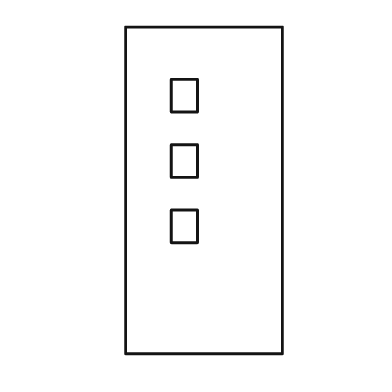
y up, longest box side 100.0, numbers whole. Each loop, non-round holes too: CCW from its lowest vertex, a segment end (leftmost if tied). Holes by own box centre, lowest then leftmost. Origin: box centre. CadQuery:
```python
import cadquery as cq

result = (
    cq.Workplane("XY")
    .moveTo(-24.0, -50.0)
    .lineTo(24.0, -50.0)
    .lineTo(24.0, 50.0)
    .lineTo(-24.0, 50.0)
    .close()
    .moveTo(-10.0, -16.0)
    .lineTo(-2.0, -16.0)
    .lineTo(-2.0, -6.0)
    .lineTo(-10.0, -6.0)
    .close()
    .moveTo(-10.0, 4.0)
    .lineTo(-2.0, 4.0)
    .lineTo(-2.0, 14.0)
    .lineTo(-10.0, 14.0)
    .close()
    .moveTo(-10.0, 24.0)
    .lineTo(-2.0, 24.0)
    .lineTo(-2.0, 34.0)
    .lineTo(-10.0, 34.0)
    .close()
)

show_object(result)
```